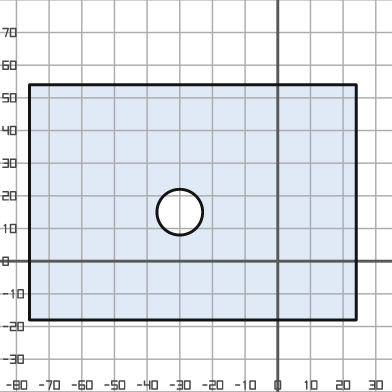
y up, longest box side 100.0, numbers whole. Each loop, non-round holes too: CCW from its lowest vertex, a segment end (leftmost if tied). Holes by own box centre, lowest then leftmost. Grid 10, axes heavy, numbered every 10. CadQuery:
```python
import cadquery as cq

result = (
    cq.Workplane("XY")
    .moveTo(-76.0, -18.0)
    .lineTo(24.0, -18.0)
    .lineTo(24.0, 54.0)
    .lineTo(-76.0, 54.0)
    .close()
    .moveTo(-30.0, 15.0)
    .circle(7.0)
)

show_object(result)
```